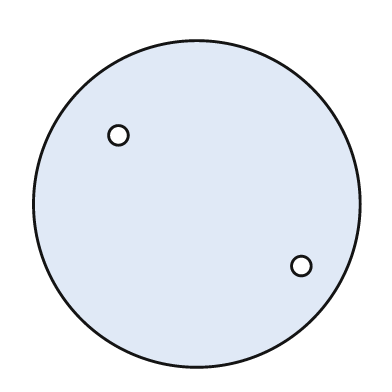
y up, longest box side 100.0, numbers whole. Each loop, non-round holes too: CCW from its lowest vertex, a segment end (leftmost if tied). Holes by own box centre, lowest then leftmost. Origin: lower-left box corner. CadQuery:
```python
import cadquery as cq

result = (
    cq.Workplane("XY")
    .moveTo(50.0, 50.0)
    .circle(50.0)
    .moveTo(82.0, 31.0)
    .circle(3.0)
    .moveTo(26.0, 71.0)
    .circle(3.0)
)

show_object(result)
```